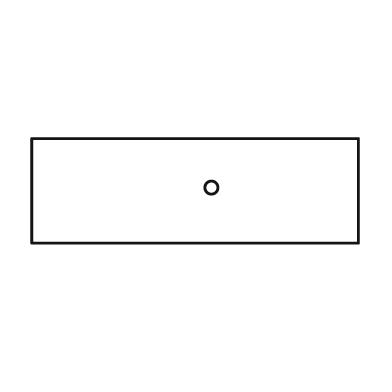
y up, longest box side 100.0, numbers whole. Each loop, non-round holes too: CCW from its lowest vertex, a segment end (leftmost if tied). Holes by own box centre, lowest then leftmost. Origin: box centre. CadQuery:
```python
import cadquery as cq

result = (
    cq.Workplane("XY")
    .moveTo(-50.0, -16.0)
    .lineTo(50.0, -16.0)
    .lineTo(50.0, 16.0)
    .lineTo(-50.0, 16.0)
    .close()
    .moveTo(5.0, 1.0)
    .circle(2.0)
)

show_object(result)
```